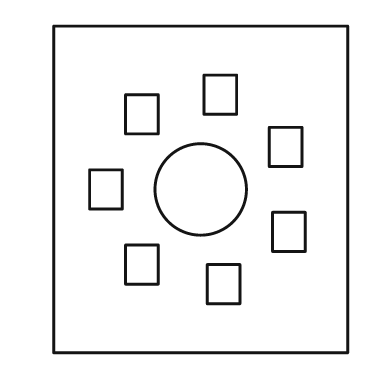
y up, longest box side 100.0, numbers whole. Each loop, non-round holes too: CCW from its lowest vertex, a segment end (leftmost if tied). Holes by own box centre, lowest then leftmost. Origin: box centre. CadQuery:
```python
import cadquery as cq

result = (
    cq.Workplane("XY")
    .moveTo(-45.0, -50.0)
    .lineTo(45.0, -50.0)
    .lineTo(45.0, 50.0)
    .lineTo(-45.0, 50.0)
    .close()
    .moveTo(2.0, -35.0)
    .lineTo(12.0, -35.0)
    .lineTo(12.0, -23.0)
    .lineTo(2.0, -23.0)
    .close()
    .moveTo(-23.0, -29.0)
    .lineTo(-13.0, -29.0)
    .lineTo(-13.0, -17.0)
    .lineTo(-23.0, -17.0)
    .close()
    .moveTo(22.0, -19.0)
    .lineTo(32.0, -19.0)
    .lineTo(32.0, -7.0)
    .lineTo(22.0, -7.0)
    .close()
    .moveTo(-34.0, -6.0)
    .lineTo(-24.0, -6.0)
    .lineTo(-24.0, 6.0)
    .lineTo(-34.0, 6.0)
    .close()
    .moveTo(0.0, 0.0)
    .circle(14.0)
    .moveTo(21.0, 7.0)
    .lineTo(31.0, 7.0)
    .lineTo(31.0, 19.0)
    .lineTo(21.0, 19.0)
    .close()
    .moveTo(-23.0, 17.0)
    .lineTo(-13.0, 17.0)
    .lineTo(-13.0, 29.0)
    .lineTo(-23.0, 29.0)
    .close()
    .moveTo(1.0, 23.0)
    .lineTo(11.0, 23.0)
    .lineTo(11.0, 35.0)
    .lineTo(1.0, 35.0)
    .close()
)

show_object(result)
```